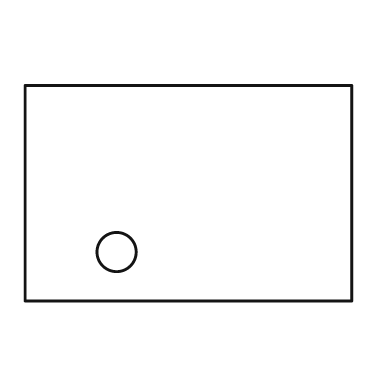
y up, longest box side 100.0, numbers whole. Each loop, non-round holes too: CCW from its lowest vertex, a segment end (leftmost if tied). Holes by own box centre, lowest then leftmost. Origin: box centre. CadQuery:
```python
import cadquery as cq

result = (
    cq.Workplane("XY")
    .moveTo(-50.0, -33.0)
    .lineTo(50.0, -33.0)
    .lineTo(50.0, 33.0)
    .lineTo(-50.0, 33.0)
    .close()
    .moveTo(-22.0, -18.0)
    .circle(6.0)
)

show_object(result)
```